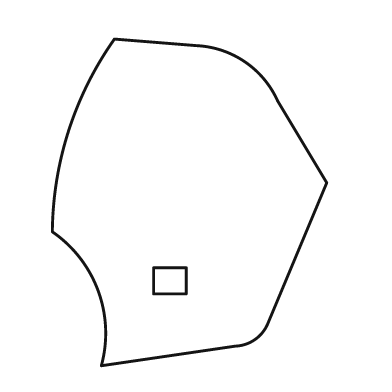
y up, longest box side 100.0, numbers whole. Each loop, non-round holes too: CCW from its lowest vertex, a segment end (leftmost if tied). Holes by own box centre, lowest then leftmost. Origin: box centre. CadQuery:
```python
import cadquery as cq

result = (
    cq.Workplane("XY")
    .moveTo(-27.0, -50.0)
    .lineTo(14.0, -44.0)
    .threePointArc((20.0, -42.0), (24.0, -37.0))
    .lineTo(42.0, 6.0)
    .lineTo(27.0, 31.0)
    .threePointArc((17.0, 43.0), (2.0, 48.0))
    .lineTo(-23.0, 50.0)
    .threePointArc((-37.0, 22.0), (-42.0, -9.0))
    .threePointArc((-28.0, -27.0), (-27.0, -50.0))
    .close()
    .moveTo(-11.0, -28.0)
    .lineTo(-1.0, -28.0)
    .lineTo(-1.0, -20.0)
    .lineTo(-11.0, -20.0)
    .close()
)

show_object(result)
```